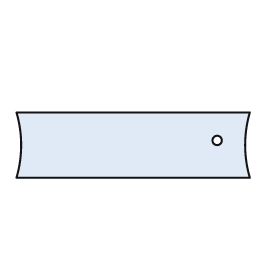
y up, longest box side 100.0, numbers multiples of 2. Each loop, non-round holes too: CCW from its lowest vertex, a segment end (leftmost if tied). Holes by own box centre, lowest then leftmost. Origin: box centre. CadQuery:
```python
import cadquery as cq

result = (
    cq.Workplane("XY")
    .moveTo(-50.0, -14.0)
    .lineTo(50.0, -14.0)
    .threePointArc((48.0, 0.0), (50.0, 14.0))
    .lineTo(-50.0, 14.0)
    .threePointArc((-48.0, 0.0), (-50.0, -14.0))
    .close()
    .moveTo(36.0, 2.0)
    .circle(2.0)
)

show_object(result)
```